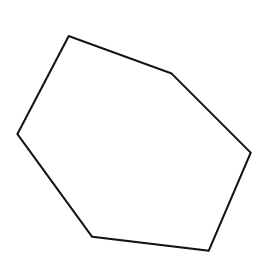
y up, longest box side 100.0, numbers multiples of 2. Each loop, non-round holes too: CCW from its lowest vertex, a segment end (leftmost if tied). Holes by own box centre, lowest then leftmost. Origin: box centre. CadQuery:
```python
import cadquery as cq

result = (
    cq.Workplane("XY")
    .moveTo(32.0, -46.0)
    .lineTo(50.0, -4.0)
    .lineTo(16.0, 30.0)
    .lineTo(-28.0, 46.0)
    .lineTo(-50.0, 4.0)
    .lineTo(-18.0, -40.0)
    .close()
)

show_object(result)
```